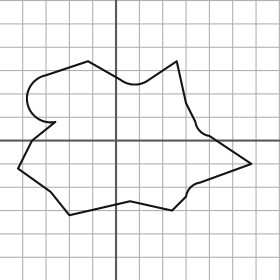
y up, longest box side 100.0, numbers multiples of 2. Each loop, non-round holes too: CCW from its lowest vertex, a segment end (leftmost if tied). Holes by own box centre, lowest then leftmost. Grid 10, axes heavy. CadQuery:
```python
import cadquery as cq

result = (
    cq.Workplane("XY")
    .moveTo(-20.0, -32.0)
    .lineTo(6.0, -26.0)
    .lineTo(24.0, -30.0)
    .lineTo(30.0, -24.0)
    .threePointArc((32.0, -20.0), (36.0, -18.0))
    .lineTo(58.0, -10.0)
    .lineTo(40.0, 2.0)
    .threePointArc((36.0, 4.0), (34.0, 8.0))
    .lineTo(30.0, 16.0)
    .lineTo(26.0, 34.0)
    .lineTo(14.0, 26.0)
    .threePointArc((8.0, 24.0), (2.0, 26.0))
    .lineTo(-12.0, 34.0)
    .lineTo(-30.0, 28.0)
    .threePointArc((-38.0, 16.0), (-26.0, 8.0))
    .lineTo(-36.0, 0.0)
    .lineTo(-42.0, -12.0)
    .lineTo(-28.0, -22.0)
    .close()
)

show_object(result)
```